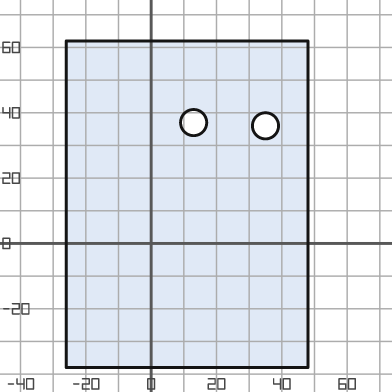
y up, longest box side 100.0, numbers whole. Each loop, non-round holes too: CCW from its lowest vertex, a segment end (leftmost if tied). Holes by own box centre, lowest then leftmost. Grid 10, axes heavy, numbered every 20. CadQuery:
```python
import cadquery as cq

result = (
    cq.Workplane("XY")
    .moveTo(-26.0, -38.0)
    .lineTo(48.0, -38.0)
    .lineTo(48.0, 62.0)
    .lineTo(-26.0, 62.0)
    .close()
    .moveTo(35.0, 36.0)
    .circle(4.0)
    .moveTo(13.0, 37.0)
    .circle(4.0)
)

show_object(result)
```